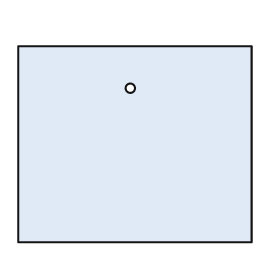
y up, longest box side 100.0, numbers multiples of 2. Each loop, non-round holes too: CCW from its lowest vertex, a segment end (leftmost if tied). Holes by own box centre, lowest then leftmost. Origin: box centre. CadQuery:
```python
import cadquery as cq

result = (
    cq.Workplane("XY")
    .moveTo(-50.0, -42.0)
    .lineTo(50.0, -42.0)
    .lineTo(50.0, 42.0)
    .lineTo(-50.0, 42.0)
    .close()
    .moveTo(-2.0, 24.0)
    .circle(2.0)
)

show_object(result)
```